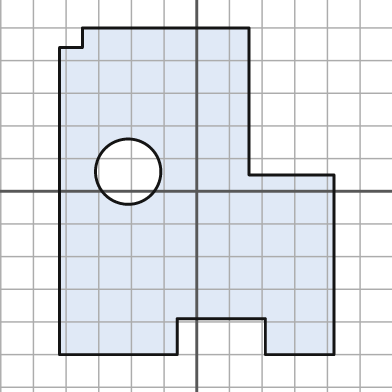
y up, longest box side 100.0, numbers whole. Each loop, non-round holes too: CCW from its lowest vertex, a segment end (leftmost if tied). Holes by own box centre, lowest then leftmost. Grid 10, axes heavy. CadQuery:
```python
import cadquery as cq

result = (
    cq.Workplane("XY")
    .moveTo(-42.0, -50.0)
    .lineTo(-6.0, -50.0)
    .lineTo(-6.0, -39.0)
    .lineTo(21.0, -39.0)
    .lineTo(21.0, -50.0)
    .lineTo(42.0, -50.0)
    .lineTo(42.0, 5.0)
    .lineTo(16.0, 5.0)
    .lineTo(16.0, 50.0)
    .lineTo(-35.0, 50.0)
    .lineTo(-35.0, 44.0)
    .lineTo(-42.0, 44.0)
    .close()
    .moveTo(-21.0, 6.0)
    .circle(10.0)
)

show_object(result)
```